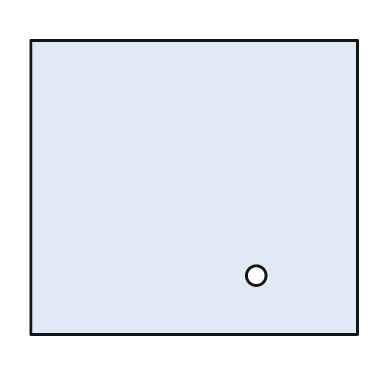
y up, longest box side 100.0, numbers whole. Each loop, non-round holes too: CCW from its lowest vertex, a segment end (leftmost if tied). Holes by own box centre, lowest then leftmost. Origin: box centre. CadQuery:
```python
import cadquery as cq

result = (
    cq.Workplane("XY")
    .moveTo(-50.0, -45.0)
    .lineTo(50.0, -45.0)
    .lineTo(50.0, 45.0)
    .lineTo(-50.0, 45.0)
    .close()
    .moveTo(19.0, -27.0)
    .circle(3.0)
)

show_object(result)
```